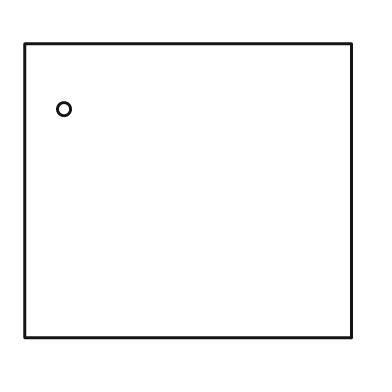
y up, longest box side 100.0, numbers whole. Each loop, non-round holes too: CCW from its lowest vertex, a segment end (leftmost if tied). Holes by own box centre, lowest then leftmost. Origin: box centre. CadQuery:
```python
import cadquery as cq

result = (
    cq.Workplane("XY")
    .moveTo(-50.0, -45.0)
    .lineTo(50.0, -45.0)
    .lineTo(50.0, 45.0)
    .lineTo(-50.0, 45.0)
    .close()
    .moveTo(-38.0, 25.0)
    .circle(2.0)
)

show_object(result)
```